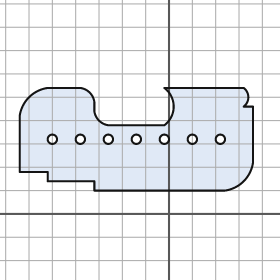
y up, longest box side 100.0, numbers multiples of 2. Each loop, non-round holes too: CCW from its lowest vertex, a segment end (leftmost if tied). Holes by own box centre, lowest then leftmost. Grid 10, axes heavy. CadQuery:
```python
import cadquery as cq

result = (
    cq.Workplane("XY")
    .moveTo(-32.0, 10.0)
    .lineTo(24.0, 10.0)
    .threePointArc((32.0, 14.0), (36.0, 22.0))
    .lineTo(36.0, 46.0)
    .lineTo(32.0, 46.0)
    .threePointArc((34.0, 50.0), (32.0, 54.0))
    .lineTo(-2.0, 54.0)
    .threePointArc((2.0, 46.0), (-2.0, 38.0))
    .lineTo(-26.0, 38.0)
    .threePointArc((-30.0, 40.0), (-32.0, 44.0))
    .lineTo(-32.0, 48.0)
    .threePointArc((-34.0, 52.0), (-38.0, 54.0))
    .lineTo(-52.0, 54.0)
    .threePointArc((-60.0, 50.0), (-64.0, 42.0))
    .lineTo(-64.0, 18.0)
    .lineTo(-52.0, 18.0)
    .lineTo(-52.0, 14.0)
    .lineTo(-32.0, 14.0)
    .close()
    .moveTo(-50.0, 32.0)
    .circle(2.0)
    .moveTo(-38.0, 32.0)
    .circle(2.0)
    .moveTo(-26.0, 32.0)
    .circle(2.0)
    .moveTo(-14.0, 32.0)
    .circle(2.0)
    .moveTo(-2.0, 32.0)
    .circle(2.0)
    .moveTo(10.0, 32.0)
    .circle(2.0)
    .moveTo(22.0, 32.0)
    .circle(2.0)
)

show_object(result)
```